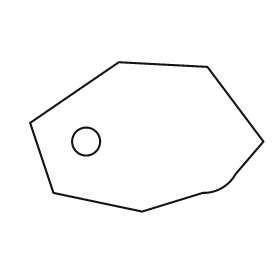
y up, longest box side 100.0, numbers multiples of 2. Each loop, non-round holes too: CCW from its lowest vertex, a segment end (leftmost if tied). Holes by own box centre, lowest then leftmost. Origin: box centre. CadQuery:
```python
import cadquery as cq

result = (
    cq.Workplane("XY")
    .moveTo(-2.0, -32.0)
    .lineTo(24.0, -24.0)
    .threePointArc((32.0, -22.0), (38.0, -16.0))
    .lineTo(50.0, -2.0)
    .lineTo(26.0, 30.0)
    .lineTo(-12.0, 32.0)
    .lineTo(-50.0, 6.0)
    .lineTo(-40.0, -24.0)
    .close()
    .moveTo(-26.0, -2.0)
    .circle(6.0)
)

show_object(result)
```